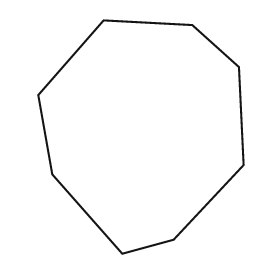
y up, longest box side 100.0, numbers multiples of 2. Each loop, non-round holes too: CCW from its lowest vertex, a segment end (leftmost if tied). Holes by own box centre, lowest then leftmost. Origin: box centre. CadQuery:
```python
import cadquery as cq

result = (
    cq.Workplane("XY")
    .moveTo(-8.0, -50.0)
    .lineTo(14.0, -44.0)
    .lineTo(44.0, -12.0)
    .lineTo(42.0, 30.0)
    .lineTo(22.0, 48.0)
    .lineTo(-16.0, 50.0)
    .lineTo(-44.0, 18.0)
    .lineTo(-38.0, -16.0)
    .close()
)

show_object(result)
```